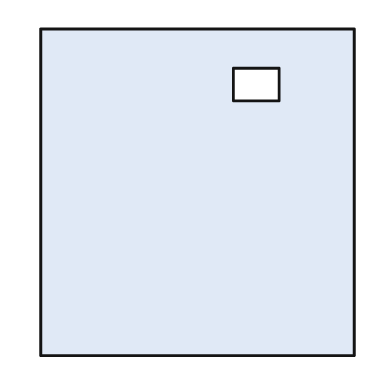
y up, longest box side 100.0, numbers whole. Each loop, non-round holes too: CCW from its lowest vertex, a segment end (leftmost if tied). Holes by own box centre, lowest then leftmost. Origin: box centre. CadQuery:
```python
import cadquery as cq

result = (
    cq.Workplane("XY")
    .moveTo(-48.0, -50.0)
    .lineTo(48.0, -50.0)
    .lineTo(48.0, 50.0)
    .lineTo(-48.0, 50.0)
    .close()
    .moveTo(11.0, 28.0)
    .lineTo(25.0, 28.0)
    .lineTo(25.0, 38.0)
    .lineTo(11.0, 38.0)
    .close()
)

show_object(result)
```